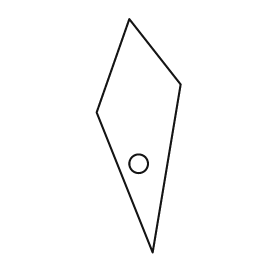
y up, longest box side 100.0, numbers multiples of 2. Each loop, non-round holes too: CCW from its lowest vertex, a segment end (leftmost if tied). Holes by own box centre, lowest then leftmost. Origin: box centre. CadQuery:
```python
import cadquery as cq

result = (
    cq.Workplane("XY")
    .moveTo(6.0, -50.0)
    .lineTo(18.0, 22.0)
    .lineTo(-4.0, 50.0)
    .lineTo(-18.0, 10.0)
    .close()
    .moveTo(0.0, -12.0)
    .circle(4.0)
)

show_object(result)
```